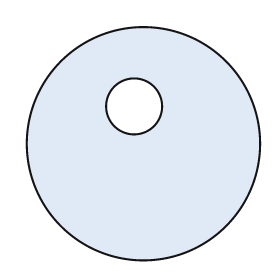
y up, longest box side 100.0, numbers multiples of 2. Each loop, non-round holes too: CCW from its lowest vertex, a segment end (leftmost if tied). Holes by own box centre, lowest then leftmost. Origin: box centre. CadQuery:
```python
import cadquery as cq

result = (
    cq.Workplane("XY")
    .moveTo(0.0, 0.0)
    .circle(50.0)
    .moveTo(-4.0, 16.0)
    .circle(12.0)
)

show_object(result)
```